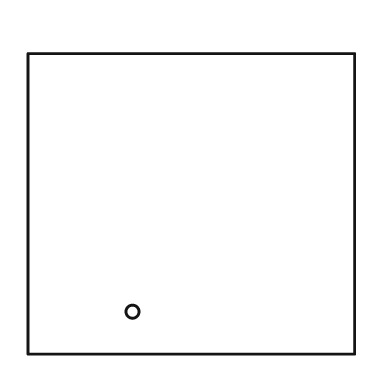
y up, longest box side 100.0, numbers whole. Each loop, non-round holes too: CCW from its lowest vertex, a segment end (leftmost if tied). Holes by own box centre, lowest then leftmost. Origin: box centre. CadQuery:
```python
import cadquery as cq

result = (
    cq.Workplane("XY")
    .moveTo(-50.0, -46.0)
    .lineTo(50.0, -46.0)
    .lineTo(50.0, 46.0)
    .lineTo(-50.0, 46.0)
    .close()
    .moveTo(-18.0, -33.0)
    .circle(2.0)
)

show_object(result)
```